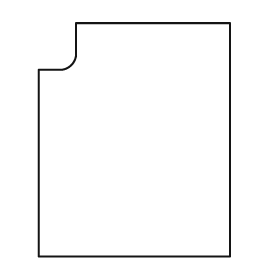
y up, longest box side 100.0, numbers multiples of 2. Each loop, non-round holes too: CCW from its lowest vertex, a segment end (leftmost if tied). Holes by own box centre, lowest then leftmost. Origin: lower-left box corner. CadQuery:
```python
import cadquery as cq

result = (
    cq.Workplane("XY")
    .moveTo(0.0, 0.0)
    .lineTo(82.0, 0.0)
    .lineTo(82.0, 100.0)
    .lineTo(16.0, 100.0)
    .lineTo(16.0, 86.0)
    .threePointArc((14.0, 82.0), (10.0, 80.0))
    .lineTo(0.0, 80.0)
    .close()
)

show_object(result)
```